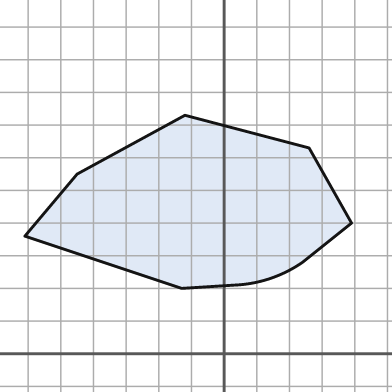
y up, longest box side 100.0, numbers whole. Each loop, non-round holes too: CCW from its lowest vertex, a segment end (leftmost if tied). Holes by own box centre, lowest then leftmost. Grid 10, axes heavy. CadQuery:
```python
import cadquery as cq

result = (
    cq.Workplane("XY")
    .moveTo(-13.0, 20.0)
    .lineTo(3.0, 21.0)
    .threePointArc((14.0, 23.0), (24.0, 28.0))
    .lineTo(39.0, 40.0)
    .lineTo(26.0, 63.0)
    .lineTo(-12.0, 73.0)
    .lineTo(-45.0, 55.0)
    .lineTo(-61.0, 36.0)
    .close()
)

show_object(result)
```